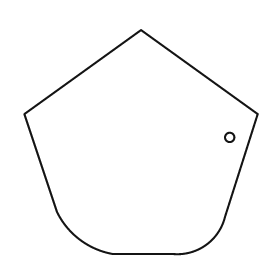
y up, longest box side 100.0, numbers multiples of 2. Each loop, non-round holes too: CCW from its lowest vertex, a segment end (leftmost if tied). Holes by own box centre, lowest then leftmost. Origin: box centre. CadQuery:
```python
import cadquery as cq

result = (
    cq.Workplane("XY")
    .moveTo(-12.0, -48.0)
    .lineTo(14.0, -48.0)
    .threePointArc((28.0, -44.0), (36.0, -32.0))
    .lineTo(50.0, 12.0)
    .lineTo(0.0, 48.0)
    .lineTo(-50.0, 12.0)
    .lineTo(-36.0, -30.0)
    .threePointArc((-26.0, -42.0), (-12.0, -48.0))
    .close()
    .moveTo(38.0, 2.0)
    .circle(2.0)
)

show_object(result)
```